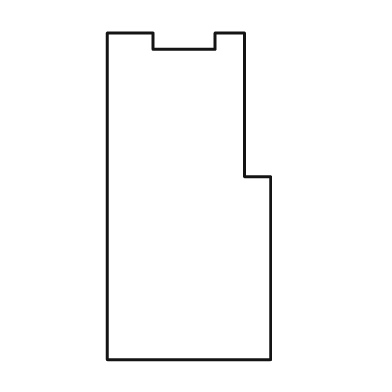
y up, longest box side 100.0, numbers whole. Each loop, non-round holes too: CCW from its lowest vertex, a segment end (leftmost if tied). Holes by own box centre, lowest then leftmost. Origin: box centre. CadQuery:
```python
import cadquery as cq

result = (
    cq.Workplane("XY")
    .moveTo(-25.0, -50.0)
    .lineTo(25.0, -50.0)
    .lineTo(25.0, 6.0)
    .lineTo(17.0, 6.0)
    .lineTo(17.0, 50.0)
    .lineTo(8.0, 50.0)
    .lineTo(8.0, 45.0)
    .lineTo(-11.0, 45.0)
    .lineTo(-11.0, 50.0)
    .lineTo(-25.0, 50.0)
    .close()
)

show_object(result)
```